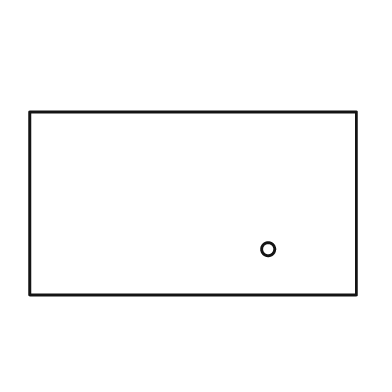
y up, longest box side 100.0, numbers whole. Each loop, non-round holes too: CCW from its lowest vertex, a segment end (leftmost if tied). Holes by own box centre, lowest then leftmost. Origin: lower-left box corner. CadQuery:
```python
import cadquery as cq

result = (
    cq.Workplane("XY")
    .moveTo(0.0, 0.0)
    .lineTo(100.0, 0.0)
    .lineTo(100.0, 56.0)
    .lineTo(0.0, 56.0)
    .close()
    .moveTo(73.0, 14.0)
    .circle(2.0)
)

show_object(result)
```